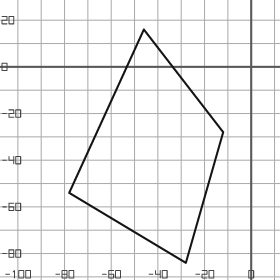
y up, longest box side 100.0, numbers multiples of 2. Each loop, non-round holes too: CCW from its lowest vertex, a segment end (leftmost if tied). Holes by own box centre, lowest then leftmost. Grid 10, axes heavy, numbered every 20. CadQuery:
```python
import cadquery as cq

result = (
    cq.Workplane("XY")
    .moveTo(-28.0, -84.0)
    .lineTo(-12.0, -28.0)
    .lineTo(-46.0, 16.0)
    .lineTo(-78.0, -54.0)
    .close()
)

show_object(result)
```